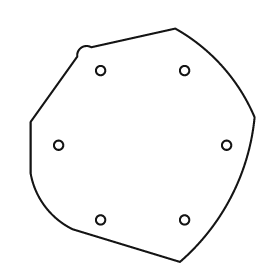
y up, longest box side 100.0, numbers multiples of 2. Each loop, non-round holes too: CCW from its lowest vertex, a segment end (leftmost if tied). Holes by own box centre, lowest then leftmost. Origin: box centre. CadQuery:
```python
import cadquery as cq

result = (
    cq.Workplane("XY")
    .moveTo(16.0, -50.0)
    .threePointArc((38.0, -22.0), (48.0, 12.0))
    .threePointArc((34.0, 34.0), (14.0, 50.0))
    .lineTo(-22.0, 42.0)
    .threePointArc((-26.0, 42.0), (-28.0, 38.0))
    .lineTo(-48.0, 10.0)
    .lineTo(-48.0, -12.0)
    .threePointArc((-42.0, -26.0), (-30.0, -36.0))
    .close()
    .moveTo(-18.0, -32.0)
    .circle(2.0)
    .moveTo(18.0, -32.0)
    .circle(2.0)
    .moveTo(-36.0, 0.0)
    .circle(2.0)
    .moveTo(36.0, 0.0)
    .circle(2.0)
    .moveTo(-18.0, 32.0)
    .circle(2.0)
    .moveTo(18.0, 32.0)
    .circle(2.0)
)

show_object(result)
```